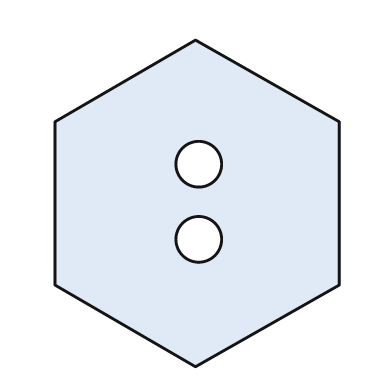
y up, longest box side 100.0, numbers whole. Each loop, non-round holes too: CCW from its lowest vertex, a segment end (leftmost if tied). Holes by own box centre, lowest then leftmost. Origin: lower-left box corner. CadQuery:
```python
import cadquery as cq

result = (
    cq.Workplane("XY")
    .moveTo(43.0, 0.0)
    .lineTo(87.0, 25.0)
    .lineTo(87.0, 75.0)
    .lineTo(43.0, 100.0)
    .lineTo(0.0, 75.0)
    .lineTo(0.0, 25.0)
    .close()
    .moveTo(44.0, 39.0)
    .circle(7.0)
    .moveTo(44.0, 62.0)
    .circle(7.0)
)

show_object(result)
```